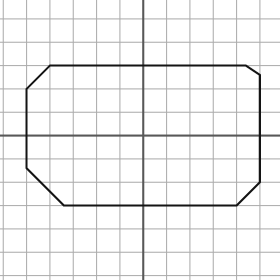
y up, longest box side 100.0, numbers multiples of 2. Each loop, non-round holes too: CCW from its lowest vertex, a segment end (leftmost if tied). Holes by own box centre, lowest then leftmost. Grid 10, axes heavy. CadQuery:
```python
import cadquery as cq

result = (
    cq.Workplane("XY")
    .moveTo(-34.0, -30.0)
    .lineTo(40.0, -30.0)
    .lineTo(50.0, -20.0)
    .lineTo(50.0, 26.0)
    .lineTo(44.0, 30.0)
    .lineTo(-40.0, 30.0)
    .lineTo(-50.0, 20.0)
    .lineTo(-50.0, -14.0)
    .close()
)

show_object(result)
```